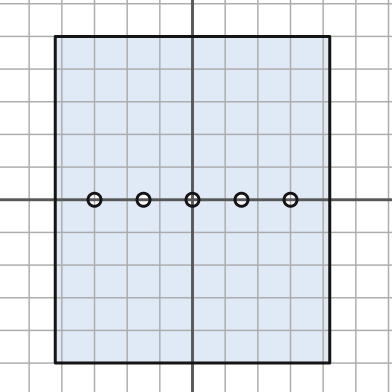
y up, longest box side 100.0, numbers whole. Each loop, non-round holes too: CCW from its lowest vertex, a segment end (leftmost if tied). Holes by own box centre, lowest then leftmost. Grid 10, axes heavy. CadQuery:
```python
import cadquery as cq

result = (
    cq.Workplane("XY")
    .moveTo(-42.0, -50.0)
    .lineTo(42.0, -50.0)
    .lineTo(42.0, 50.0)
    .lineTo(-42.0, 50.0)
    .close()
    .moveTo(-30.0, 0.0)
    .circle(2.0)
    .moveTo(-15.0, 0.0)
    .circle(2.0)
    .moveTo(0.0, 0.0)
    .circle(2.0)
    .moveTo(15.0, 0.0)
    .circle(2.0)
    .moveTo(30.0, 0.0)
    .circle(2.0)
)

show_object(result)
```